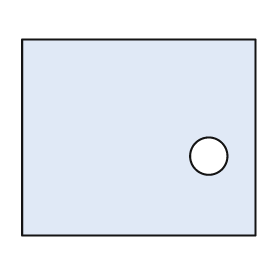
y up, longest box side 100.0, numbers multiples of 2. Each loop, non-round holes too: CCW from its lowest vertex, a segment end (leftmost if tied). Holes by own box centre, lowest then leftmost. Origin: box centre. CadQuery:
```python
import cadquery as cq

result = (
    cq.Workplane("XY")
    .moveTo(-50.0, -42.0)
    .lineTo(50.0, -42.0)
    .lineTo(50.0, 42.0)
    .lineTo(-50.0, 42.0)
    .close()
    .moveTo(30.0, -8.0)
    .circle(8.0)
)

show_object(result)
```